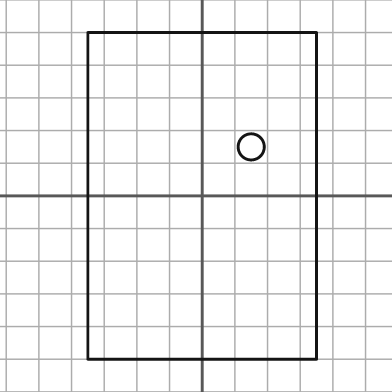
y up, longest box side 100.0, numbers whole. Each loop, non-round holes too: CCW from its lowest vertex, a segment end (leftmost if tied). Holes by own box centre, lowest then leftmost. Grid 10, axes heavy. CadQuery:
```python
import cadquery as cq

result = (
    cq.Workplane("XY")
    .moveTo(-35.0, -50.0)
    .lineTo(35.0, -50.0)
    .lineTo(35.0, 50.0)
    .lineTo(-35.0, 50.0)
    .close()
    .moveTo(15.0, 15.0)
    .circle(4.0)
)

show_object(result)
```